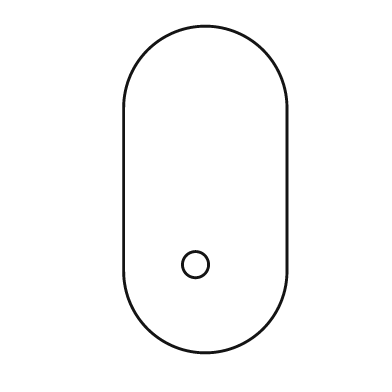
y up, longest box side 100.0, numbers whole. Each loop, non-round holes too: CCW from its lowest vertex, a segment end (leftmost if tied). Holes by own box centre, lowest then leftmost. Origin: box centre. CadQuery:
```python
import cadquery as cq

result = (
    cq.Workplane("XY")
    .moveTo(-25.0, -25.0)
    .threePointArc((0.0, -50.0), (25.0, -25.0))
    .lineTo(25.0, 25.0)
    .threePointArc((0.0, 50.0), (-25.0, 25.0))
    .close()
    .moveTo(-3.0, -23.0)
    .circle(4.0)
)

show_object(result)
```